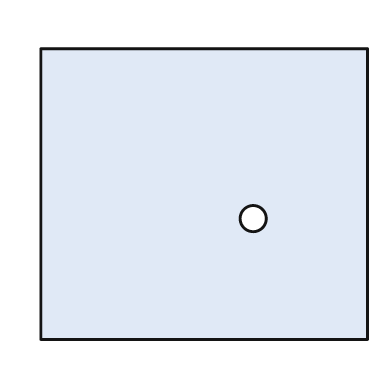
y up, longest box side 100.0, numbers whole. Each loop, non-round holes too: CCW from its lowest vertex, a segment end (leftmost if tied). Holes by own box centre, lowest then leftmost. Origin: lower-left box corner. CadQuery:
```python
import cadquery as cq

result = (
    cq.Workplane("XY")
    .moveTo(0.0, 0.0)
    .lineTo(100.0, 0.0)
    .lineTo(100.0, 89.0)
    .lineTo(0.0, 89.0)
    .close()
    .moveTo(65.0, 37.0)
    .circle(4.0)
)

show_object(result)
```